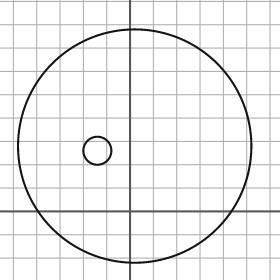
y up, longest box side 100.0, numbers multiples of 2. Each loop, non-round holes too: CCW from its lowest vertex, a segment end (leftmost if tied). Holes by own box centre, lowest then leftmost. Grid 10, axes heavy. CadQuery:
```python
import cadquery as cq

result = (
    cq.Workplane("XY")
    .moveTo(2.0, 28.0)
    .circle(50.0)
    .moveTo(-14.0, 26.0)
    .circle(6.0)
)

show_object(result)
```